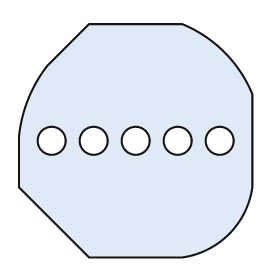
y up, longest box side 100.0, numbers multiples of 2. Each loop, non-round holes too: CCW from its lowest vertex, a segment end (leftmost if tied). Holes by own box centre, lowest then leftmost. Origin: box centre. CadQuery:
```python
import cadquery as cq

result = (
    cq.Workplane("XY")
    .moveTo(-20.0, -50.0)
    .lineTo(20.0, -50.0)
    .threePointArc((40.0, -40.0), (50.0, -20.0))
    .lineTo(50.0, 20.0)
    .threePointArc((38.0, 38.0), (20.0, 50.0))
    .lineTo(-20.0, 50.0)
    .lineTo(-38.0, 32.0)
    .threePointArc((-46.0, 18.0), (-50.0, 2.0))
    .lineTo(-50.0, -20.0)
    .close()
    .moveTo(-36.0, 0.0)
    .circle(6.0)
    .moveTo(-18.0, 0.0)
    .circle(6.0)
    .moveTo(0.0, 0.0)
    .circle(6.0)
    .moveTo(18.0, 0.0)
    .circle(6.0)
    .moveTo(36.0, 0.0)
    .circle(6.0)
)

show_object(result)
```